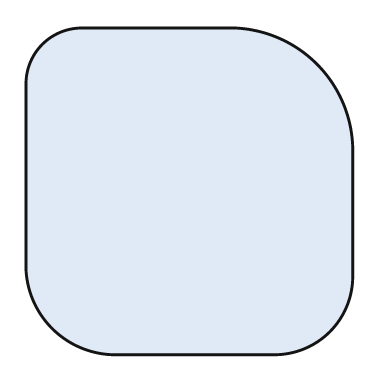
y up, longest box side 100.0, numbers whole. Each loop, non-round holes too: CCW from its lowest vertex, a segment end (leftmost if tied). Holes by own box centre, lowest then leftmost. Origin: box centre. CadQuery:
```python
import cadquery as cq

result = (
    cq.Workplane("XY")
    .moveTo(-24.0, -50.0)
    .lineTo(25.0, -50.0)
    .threePointArc((43.0, -43.0), (50.0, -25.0))
    .lineTo(50.0, 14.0)
    .threePointArc((39.0, 39.0), (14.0, 50.0))
    .lineTo(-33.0, 50.0)
    .threePointArc((-45.0, 45.0), (-50.0, 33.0))
    .lineTo(-50.0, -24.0)
    .threePointArc((-42.0, -42.0), (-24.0, -50.0))
    .close()
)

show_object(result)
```